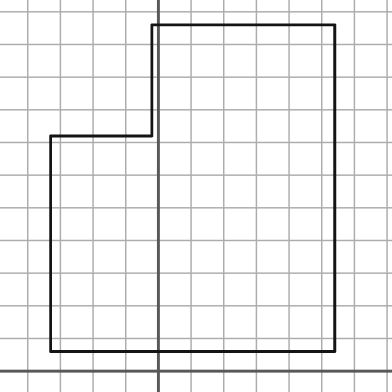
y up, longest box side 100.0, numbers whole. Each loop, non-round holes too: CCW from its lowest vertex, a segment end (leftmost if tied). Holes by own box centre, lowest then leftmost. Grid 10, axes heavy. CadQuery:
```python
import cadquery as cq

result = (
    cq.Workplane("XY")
    .moveTo(-33.0, 6.0)
    .lineTo(54.0, 6.0)
    .lineTo(54.0, 106.0)
    .lineTo(-2.0, 106.0)
    .lineTo(-2.0, 72.0)
    .lineTo(-33.0, 72.0)
    .close()
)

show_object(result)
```